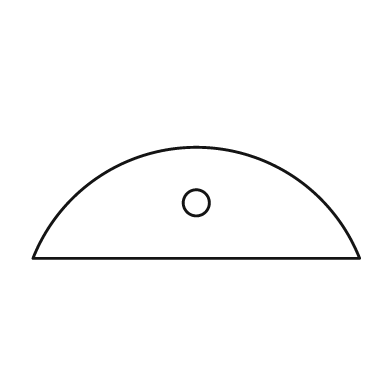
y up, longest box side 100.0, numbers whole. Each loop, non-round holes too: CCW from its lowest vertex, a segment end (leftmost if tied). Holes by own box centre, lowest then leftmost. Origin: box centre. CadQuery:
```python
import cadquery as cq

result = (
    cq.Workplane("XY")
    .moveTo(-50.0, -17.0)
    .lineTo(50.0, -17.0)
    .threePointArc((0.0, 17.0), (-50.0, -17.0))
    .close()
    .moveTo(0.0, 0.0)
    .circle(4.0)
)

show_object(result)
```